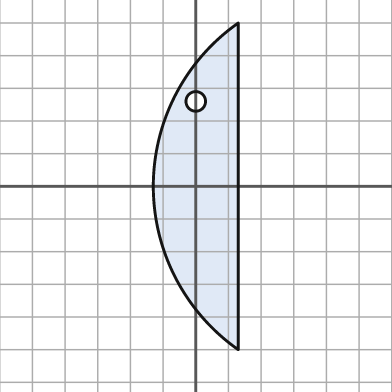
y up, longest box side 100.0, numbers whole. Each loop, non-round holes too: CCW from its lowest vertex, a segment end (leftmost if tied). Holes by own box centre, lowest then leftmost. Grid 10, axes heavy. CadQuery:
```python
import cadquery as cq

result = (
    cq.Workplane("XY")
    .moveTo(13.0, -50.0)
    .lineTo(13.0, 50.0)
    .threePointArc((-13.0, 0.0), (13.0, -50.0))
    .close()
    .moveTo(0.0, 26.0)
    .circle(3.0)
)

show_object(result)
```